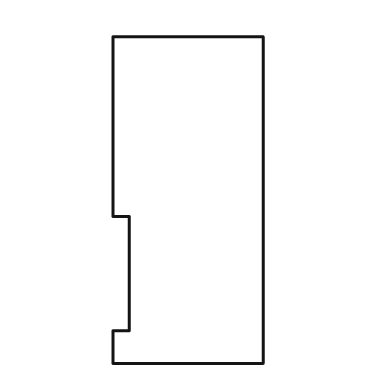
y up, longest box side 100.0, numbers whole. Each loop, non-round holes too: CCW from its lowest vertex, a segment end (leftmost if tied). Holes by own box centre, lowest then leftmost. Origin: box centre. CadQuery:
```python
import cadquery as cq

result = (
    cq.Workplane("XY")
    .moveTo(-23.0, -50.0)
    .lineTo(23.0, -50.0)
    .lineTo(23.0, 50.0)
    .lineTo(-23.0, 50.0)
    .lineTo(-23.0, -5.0)
    .lineTo(-18.0, -5.0)
    .lineTo(-18.0, -40.0)
    .lineTo(-23.0, -40.0)
    .close()
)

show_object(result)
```